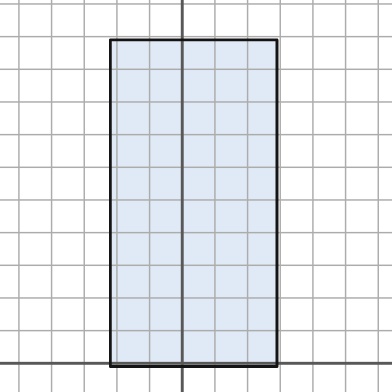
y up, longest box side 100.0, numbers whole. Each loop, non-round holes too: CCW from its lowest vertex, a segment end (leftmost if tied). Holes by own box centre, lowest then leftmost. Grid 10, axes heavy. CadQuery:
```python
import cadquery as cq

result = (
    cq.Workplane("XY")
    .moveTo(-22.0, -1.0)
    .lineTo(29.0, -1.0)
    .lineTo(29.0, 99.0)
    .lineTo(-22.0, 99.0)
    .close()
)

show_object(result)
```